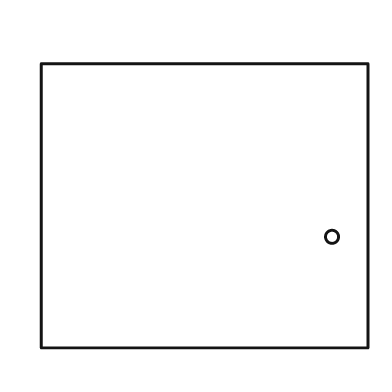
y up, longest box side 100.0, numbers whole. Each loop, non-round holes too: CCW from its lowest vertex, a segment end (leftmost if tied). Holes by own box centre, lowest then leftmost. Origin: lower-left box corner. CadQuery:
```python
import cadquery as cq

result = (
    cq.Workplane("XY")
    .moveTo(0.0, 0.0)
    .lineTo(100.0, 0.0)
    .lineTo(100.0, 87.0)
    .lineTo(0.0, 87.0)
    .close()
    .moveTo(89.0, 34.0)
    .circle(2.0)
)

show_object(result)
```